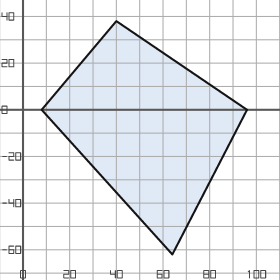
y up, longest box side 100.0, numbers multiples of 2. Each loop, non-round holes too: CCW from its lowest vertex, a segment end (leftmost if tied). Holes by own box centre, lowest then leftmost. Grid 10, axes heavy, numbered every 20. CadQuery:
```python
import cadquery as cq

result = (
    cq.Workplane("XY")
    .moveTo(64.0, -62.0)
    .lineTo(96.0, 0.0)
    .lineTo(40.0, 38.0)
    .lineTo(8.0, 0.0)
    .close()
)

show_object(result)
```